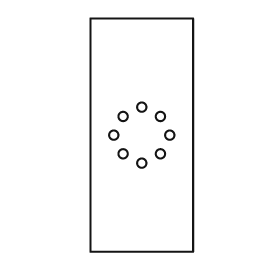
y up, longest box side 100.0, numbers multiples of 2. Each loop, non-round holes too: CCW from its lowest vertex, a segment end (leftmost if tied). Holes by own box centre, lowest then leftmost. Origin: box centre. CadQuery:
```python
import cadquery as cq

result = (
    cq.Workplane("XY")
    .moveTo(-22.0, -50.0)
    .lineTo(22.0, -50.0)
    .lineTo(22.0, 50.0)
    .lineTo(-22.0, 50.0)
    .close()
    .moveTo(0.0, -12.0)
    .circle(2.0)
    .moveTo(-8.0, -8.0)
    .circle(2.0)
    .moveTo(8.0, -8.0)
    .circle(2.0)
    .moveTo(-12.0, 0.0)
    .circle(2.0)
    .moveTo(12.0, 0.0)
    .circle(2.0)
    .moveTo(-8.0, 8.0)
    .circle(2.0)
    .moveTo(8.0, 8.0)
    .circle(2.0)
    .moveTo(0.0, 12.0)
    .circle(2.0)
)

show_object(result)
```